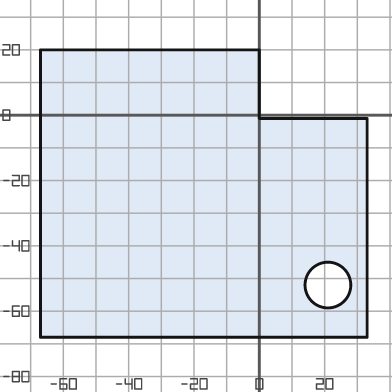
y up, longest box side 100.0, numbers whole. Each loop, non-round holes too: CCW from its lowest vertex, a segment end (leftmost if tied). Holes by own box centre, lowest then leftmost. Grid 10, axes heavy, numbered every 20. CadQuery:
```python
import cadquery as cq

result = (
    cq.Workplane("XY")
    .moveTo(-67.0, -68.0)
    .lineTo(33.0, -68.0)
    .lineTo(33.0, -1.0)
    .lineTo(0.0, -1.0)
    .lineTo(0.0, 20.0)
    .lineTo(-67.0, 20.0)
    .close()
    .moveTo(21.0, -52.0)
    .circle(7.0)
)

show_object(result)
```